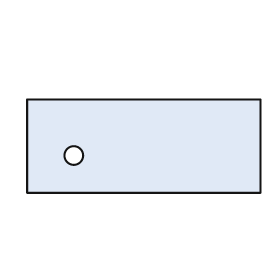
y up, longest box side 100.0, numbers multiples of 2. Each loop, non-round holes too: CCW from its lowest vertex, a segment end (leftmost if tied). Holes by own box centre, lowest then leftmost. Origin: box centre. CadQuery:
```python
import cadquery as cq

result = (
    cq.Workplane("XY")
    .moveTo(-50.0, -20.0)
    .lineTo(50.0, -20.0)
    .lineTo(50.0, 20.0)
    .lineTo(-50.0, 20.0)
    .close()
    .moveTo(-30.0, -4.0)
    .circle(4.0)
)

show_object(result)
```